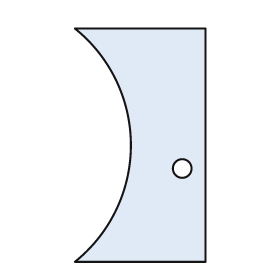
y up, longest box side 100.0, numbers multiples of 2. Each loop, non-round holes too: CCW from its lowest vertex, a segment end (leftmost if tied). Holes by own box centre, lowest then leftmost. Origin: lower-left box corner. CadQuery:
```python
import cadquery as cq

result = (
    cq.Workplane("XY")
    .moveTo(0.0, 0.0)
    .lineTo(56.0, 0.0)
    .lineTo(56.0, 100.0)
    .lineTo(0.0, 100.0)
    .threePointArc((24.0, 50.0), (0.0, 0.0))
    .close()
    .moveTo(46.0, 40.0)
    .circle(4.0)
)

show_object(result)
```